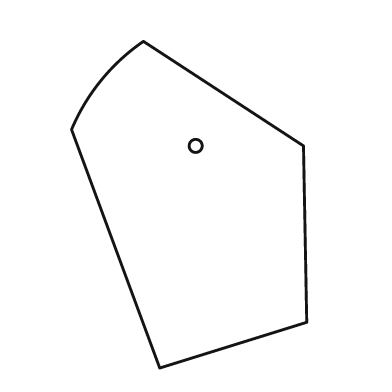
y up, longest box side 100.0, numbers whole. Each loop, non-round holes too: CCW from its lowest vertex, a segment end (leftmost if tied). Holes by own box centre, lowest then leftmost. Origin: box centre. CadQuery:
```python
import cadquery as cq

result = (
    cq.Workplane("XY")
    .moveTo(-9.0, -50.0)
    .lineTo(36.0, -36.0)
    .lineTo(35.0, 18.0)
    .lineTo(-14.0, 50.0)
    .threePointArc((-27.0, 38.0), (-36.0, 23.0))
    .close()
    .moveTo(2.0, 18.0)
    .circle(2.0)
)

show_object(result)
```